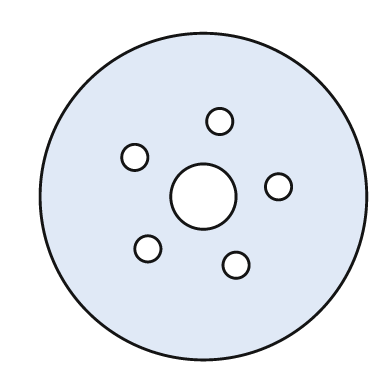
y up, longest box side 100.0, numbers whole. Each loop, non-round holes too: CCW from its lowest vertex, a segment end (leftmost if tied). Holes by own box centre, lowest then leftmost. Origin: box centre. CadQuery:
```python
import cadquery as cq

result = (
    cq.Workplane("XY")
    .moveTo(0.0, 0.0)
    .circle(50.0)
    .moveTo(10.0, -21.0)
    .circle(4.0)
    .moveTo(-17.0, -16.0)
    .circle(4.0)
    .moveTo(0.0, 0.0)
    .circle(10.0)
    .moveTo(23.0, 3.0)
    .circle(4.0)
    .moveTo(-21.0, 12.0)
    .circle(4.0)
    .moveTo(5.0, 23.0)
    .circle(4.0)
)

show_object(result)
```